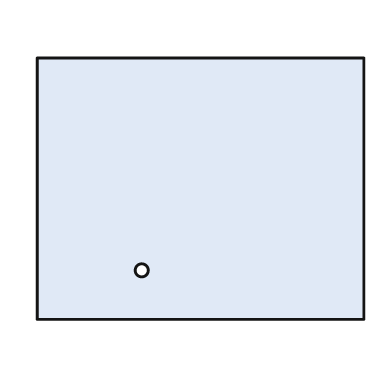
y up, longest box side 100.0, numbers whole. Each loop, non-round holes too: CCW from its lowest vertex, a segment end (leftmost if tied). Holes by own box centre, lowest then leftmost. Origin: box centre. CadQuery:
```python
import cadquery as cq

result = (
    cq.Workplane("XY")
    .moveTo(-50.0, -40.0)
    .lineTo(50.0, -40.0)
    .lineTo(50.0, 40.0)
    .lineTo(-50.0, 40.0)
    .close()
    .moveTo(-18.0, -25.0)
    .circle(2.0)
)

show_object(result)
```